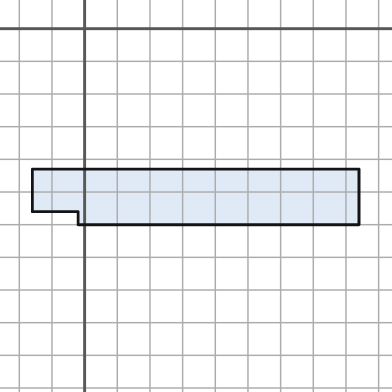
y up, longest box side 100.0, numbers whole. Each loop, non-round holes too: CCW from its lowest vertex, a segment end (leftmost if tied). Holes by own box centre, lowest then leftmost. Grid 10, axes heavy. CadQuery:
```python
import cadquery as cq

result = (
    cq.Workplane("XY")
    .moveTo(-2.0, -60.0)
    .lineTo(84.0, -60.0)
    .lineTo(84.0, -43.0)
    .lineTo(-16.0, -43.0)
    .lineTo(-16.0, -56.0)
    .lineTo(-2.0, -56.0)
    .close()
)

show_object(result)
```